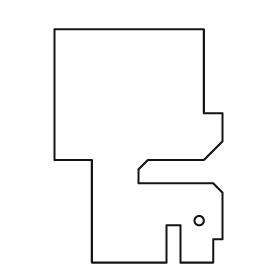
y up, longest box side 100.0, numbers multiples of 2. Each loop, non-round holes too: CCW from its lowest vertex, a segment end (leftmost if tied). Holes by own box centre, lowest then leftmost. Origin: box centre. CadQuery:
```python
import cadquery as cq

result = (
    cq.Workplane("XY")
    .moveTo(-20.0, -50.0)
    .lineTo(12.0, -50.0)
    .lineTo(12.0, -34.0)
    .lineTo(18.0, -34.0)
    .lineTo(18.0, -50.0)
    .lineTo(32.0, -50.0)
    .lineTo(32.0, -40.0)
    .lineTo(36.0, -40.0)
    .lineTo(36.0, -20.0)
    .lineTo(32.0, -16.0)
    .lineTo(0.0, -16.0)
    .lineTo(0.0, -10.0)
    .lineTo(4.0, -6.0)
    .lineTo(28.0, -6.0)
    .lineTo(36.0, 2.0)
    .lineTo(36.0, 14.0)
    .lineTo(28.0, 14.0)
    .lineTo(28.0, 50.0)
    .lineTo(-36.0, 50.0)
    .lineTo(-36.0, -6.0)
    .lineTo(-20.0, -6.0)
    .close()
    .moveTo(26.0, -32.0)
    .circle(2.0)
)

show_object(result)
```